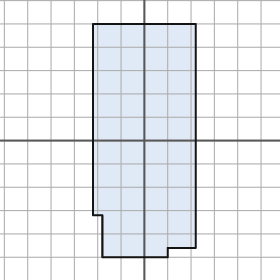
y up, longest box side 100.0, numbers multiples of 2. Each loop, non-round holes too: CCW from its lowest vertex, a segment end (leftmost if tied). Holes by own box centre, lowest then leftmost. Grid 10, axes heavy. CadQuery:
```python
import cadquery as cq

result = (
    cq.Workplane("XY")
    .moveTo(-18.0, -50.0)
    .lineTo(10.0, -50.0)
    .lineTo(10.0, -46.0)
    .lineTo(22.0, -46.0)
    .lineTo(22.0, 50.0)
    .lineTo(-22.0, 50.0)
    .lineTo(-22.0, -32.0)
    .lineTo(-18.0, -32.0)
    .close()
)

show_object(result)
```